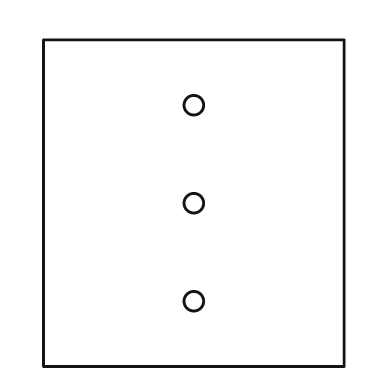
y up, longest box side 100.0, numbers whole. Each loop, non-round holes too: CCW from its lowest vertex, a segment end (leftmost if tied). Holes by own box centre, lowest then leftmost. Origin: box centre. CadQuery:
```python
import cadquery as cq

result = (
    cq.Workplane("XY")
    .moveTo(-46.0, -50.0)
    .lineTo(46.0, -50.0)
    .lineTo(46.0, 50.0)
    .lineTo(-46.0, 50.0)
    .close()
    .moveTo(0.0, -30.0)
    .circle(3.0)
    .moveTo(0.0, 0.0)
    .circle(3.0)
    .moveTo(0.0, 30.0)
    .circle(3.0)
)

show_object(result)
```